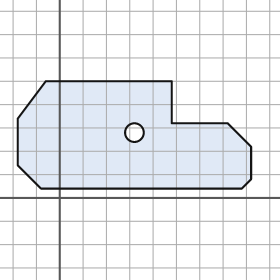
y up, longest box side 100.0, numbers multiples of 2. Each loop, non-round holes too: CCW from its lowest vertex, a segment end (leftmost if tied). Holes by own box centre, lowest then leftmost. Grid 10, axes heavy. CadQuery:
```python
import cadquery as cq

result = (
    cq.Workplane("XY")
    .moveTo(-8.0, 4.0)
    .lineTo(78.0, 4.0)
    .lineTo(82.0, 8.0)
    .lineTo(82.0, 22.0)
    .lineTo(72.0, 32.0)
    .lineTo(48.0, 32.0)
    .lineTo(48.0, 50.0)
    .lineTo(-6.0, 50.0)
    .lineTo(-18.0, 34.0)
    .lineTo(-18.0, 14.0)
    .close()
    .moveTo(32.0, 28.0)
    .circle(4.0)
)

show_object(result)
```